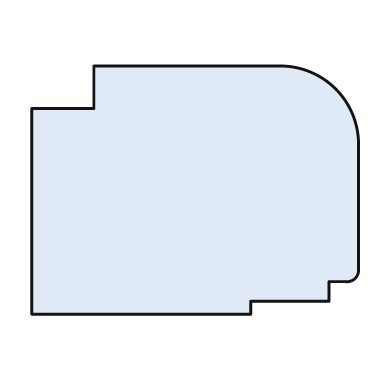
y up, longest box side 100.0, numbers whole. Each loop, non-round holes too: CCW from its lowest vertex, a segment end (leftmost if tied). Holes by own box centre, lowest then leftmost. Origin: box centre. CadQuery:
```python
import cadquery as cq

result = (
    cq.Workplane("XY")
    .moveTo(-50.0, -38.0)
    .lineTo(17.0, -38.0)
    .lineTo(17.0, -34.0)
    .lineTo(41.0, -34.0)
    .lineTo(41.0, -28.0)
    .lineTo(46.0, -28.0)
    .threePointArc((49.0, -27.0), (50.0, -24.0))
    .lineTo(50.0, 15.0)
    .threePointArc((43.0, 31.0), (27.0, 38.0))
    .lineTo(-31.0, 38.0)
    .lineTo(-31.0, 25.0)
    .lineTo(-50.0, 25.0)
    .close()
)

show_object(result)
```